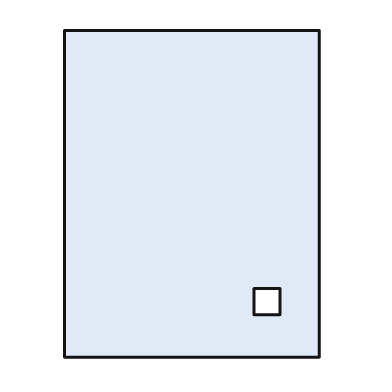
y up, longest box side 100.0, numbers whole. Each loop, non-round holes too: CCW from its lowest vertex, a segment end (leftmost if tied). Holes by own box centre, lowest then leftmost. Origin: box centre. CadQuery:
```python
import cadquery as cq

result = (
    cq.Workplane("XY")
    .moveTo(-39.0, -50.0)
    .lineTo(39.0, -50.0)
    .lineTo(39.0, 50.0)
    .lineTo(-39.0, 50.0)
    .close()
    .moveTo(19.0, -37.0)
    .lineTo(27.0, -37.0)
    .lineTo(27.0, -29.0)
    .lineTo(19.0, -29.0)
    .close()
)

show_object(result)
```